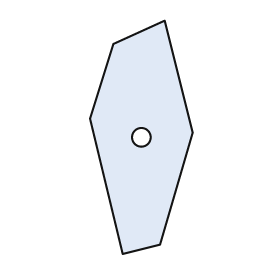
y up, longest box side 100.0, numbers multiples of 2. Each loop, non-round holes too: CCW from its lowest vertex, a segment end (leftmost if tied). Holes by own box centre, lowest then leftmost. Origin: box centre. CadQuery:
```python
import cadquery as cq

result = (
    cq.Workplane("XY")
    .moveTo(-8.0, -50.0)
    .lineTo(8.0, -46.0)
    .lineTo(22.0, 2.0)
    .lineTo(10.0, 50.0)
    .lineTo(-12.0, 40.0)
    .lineTo(-22.0, 8.0)
    .close()
    .moveTo(0.0, 0.0)
    .circle(4.0)
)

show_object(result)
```